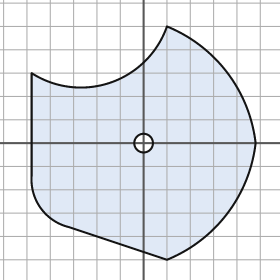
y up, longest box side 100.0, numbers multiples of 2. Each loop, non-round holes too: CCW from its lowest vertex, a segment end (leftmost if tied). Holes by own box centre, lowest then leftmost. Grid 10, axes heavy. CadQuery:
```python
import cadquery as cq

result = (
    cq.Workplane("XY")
    .moveTo(10.0, -50.0)
    .threePointArc((36.0, -30.0), (48.0, 0.0))
    .threePointArc((36.0, 30.0), (10.0, 50.0))
    .threePointArc((-14.0, 26.0), (-48.0, 30.0))
    .lineTo(-48.0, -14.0)
    .threePointArc((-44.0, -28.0), (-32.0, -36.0))
    .close()
    .moveTo(0.0, 0.0)
    .circle(4.0)
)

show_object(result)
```